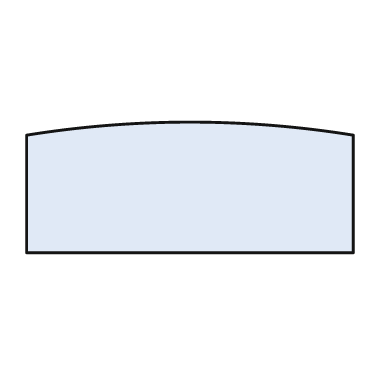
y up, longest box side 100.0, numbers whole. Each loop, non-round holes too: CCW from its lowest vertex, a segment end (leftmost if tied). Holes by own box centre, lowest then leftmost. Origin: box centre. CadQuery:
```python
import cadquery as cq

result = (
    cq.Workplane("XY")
    .moveTo(-50.0, -20.0)
    .lineTo(50.0, -20.0)
    .lineTo(50.0, 16.0)
    .threePointArc((0.0, 20.0), (-50.0, 16.0))
    .close()
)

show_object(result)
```